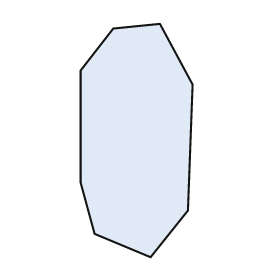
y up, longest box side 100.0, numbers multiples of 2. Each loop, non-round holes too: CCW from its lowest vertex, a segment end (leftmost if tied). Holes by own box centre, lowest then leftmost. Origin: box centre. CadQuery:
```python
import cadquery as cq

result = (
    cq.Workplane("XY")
    .moveTo(6.0, -50.0)
    .lineTo(22.0, -30.0)
    .lineTo(24.0, 24.0)
    .lineTo(10.0, 50.0)
    .lineTo(-10.0, 48.0)
    .lineTo(-24.0, 30.0)
    .lineTo(-24.0, -18.0)
    .lineTo(-18.0, -40.0)
    .close()
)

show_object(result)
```